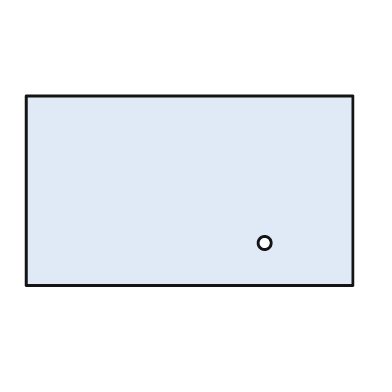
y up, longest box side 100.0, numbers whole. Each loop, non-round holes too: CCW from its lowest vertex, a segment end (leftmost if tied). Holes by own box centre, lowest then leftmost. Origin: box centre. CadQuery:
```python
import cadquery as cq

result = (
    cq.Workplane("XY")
    .moveTo(-50.0, -29.0)
    .lineTo(50.0, -29.0)
    .lineTo(50.0, 29.0)
    .lineTo(-50.0, 29.0)
    .close()
    .moveTo(23.0, -16.0)
    .circle(2.0)
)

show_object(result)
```